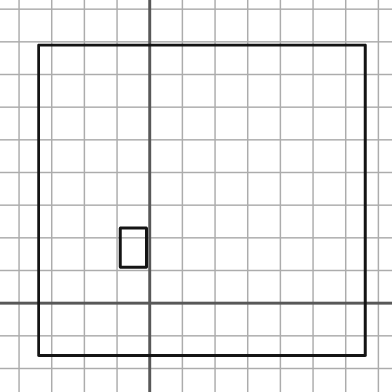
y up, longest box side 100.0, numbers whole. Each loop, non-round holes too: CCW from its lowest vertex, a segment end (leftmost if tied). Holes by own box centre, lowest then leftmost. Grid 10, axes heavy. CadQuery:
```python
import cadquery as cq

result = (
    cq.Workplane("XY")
    .moveTo(-34.0, -16.0)
    .lineTo(66.0, -16.0)
    .lineTo(66.0, 79.0)
    .lineTo(-34.0, 79.0)
    .close()
    .moveTo(-9.0, 11.0)
    .lineTo(-1.0, 11.0)
    .lineTo(-1.0, 23.0)
    .lineTo(-9.0, 23.0)
    .close()
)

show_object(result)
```